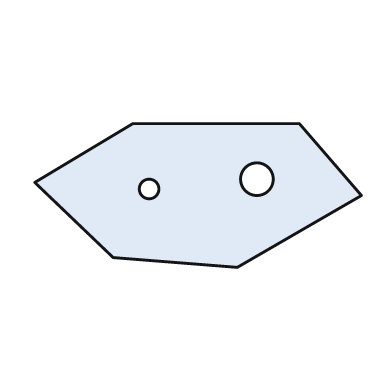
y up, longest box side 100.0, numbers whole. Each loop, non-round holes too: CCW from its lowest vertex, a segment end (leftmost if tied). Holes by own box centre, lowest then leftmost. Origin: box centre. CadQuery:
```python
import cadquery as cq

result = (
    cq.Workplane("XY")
    .moveTo(12.0, -22.0)
    .lineTo(50.0, 0.0)
    .lineTo(31.0, 22.0)
    .lineTo(-20.0, 22.0)
    .lineTo(-50.0, 4.0)
    .lineTo(-26.0, -19.0)
    .close()
    .moveTo(-15.0, 2.0)
    .circle(3.0)
    .moveTo(18.0, 5.0)
    .circle(5.0)
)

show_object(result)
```